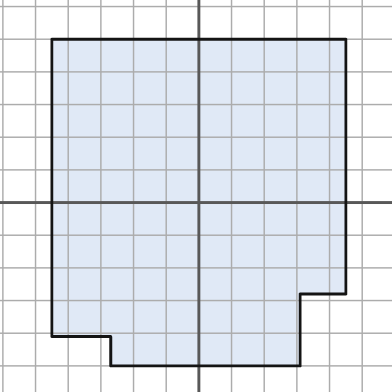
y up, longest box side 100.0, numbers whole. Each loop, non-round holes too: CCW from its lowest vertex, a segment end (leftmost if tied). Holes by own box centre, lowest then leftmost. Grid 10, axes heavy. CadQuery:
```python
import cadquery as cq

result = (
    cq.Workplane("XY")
    .moveTo(-27.0, -50.0)
    .lineTo(31.0, -50.0)
    .lineTo(31.0, -28.0)
    .lineTo(45.0, -28.0)
    .lineTo(45.0, 50.0)
    .lineTo(-45.0, 50.0)
    .lineTo(-45.0, -41.0)
    .lineTo(-27.0, -41.0)
    .close()
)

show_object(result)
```